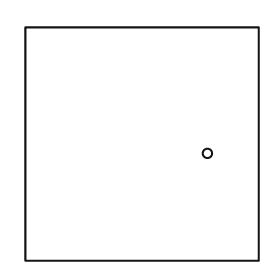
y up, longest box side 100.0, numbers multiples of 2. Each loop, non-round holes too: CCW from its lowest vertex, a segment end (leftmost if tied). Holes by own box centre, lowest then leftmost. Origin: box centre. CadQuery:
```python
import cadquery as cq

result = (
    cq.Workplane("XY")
    .moveTo(-50.0, -50.0)
    .lineTo(50.0, -50.0)
    .lineTo(50.0, 50.0)
    .lineTo(-50.0, 50.0)
    .close()
    .moveTo(28.0, -4.0)
    .circle(2.0)
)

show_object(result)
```